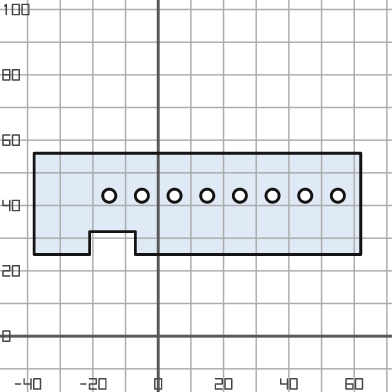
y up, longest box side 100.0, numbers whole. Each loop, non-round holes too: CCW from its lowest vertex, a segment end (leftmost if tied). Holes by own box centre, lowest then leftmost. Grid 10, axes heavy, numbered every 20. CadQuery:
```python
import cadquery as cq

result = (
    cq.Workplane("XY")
    .moveTo(-38.0, 25.0)
    .lineTo(-21.0, 25.0)
    .lineTo(-21.0, 32.0)
    .lineTo(-7.0, 32.0)
    .lineTo(-7.0, 25.0)
    .lineTo(62.0, 25.0)
    .lineTo(62.0, 56.0)
    .lineTo(-38.0, 56.0)
    .close()
    .moveTo(-15.0, 43.0)
    .circle(2.0)
    .moveTo(-5.0, 43.0)
    .circle(2.0)
    .moveTo(5.0, 43.0)
    .circle(2.0)
    .moveTo(15.0, 43.0)
    .circle(2.0)
    .moveTo(25.0, 43.0)
    .circle(2.0)
    .moveTo(35.0, 43.0)
    .circle(2.0)
    .moveTo(45.0, 43.0)
    .circle(2.0)
    .moveTo(55.0, 43.0)
    .circle(2.0)
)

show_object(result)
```